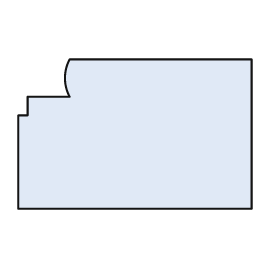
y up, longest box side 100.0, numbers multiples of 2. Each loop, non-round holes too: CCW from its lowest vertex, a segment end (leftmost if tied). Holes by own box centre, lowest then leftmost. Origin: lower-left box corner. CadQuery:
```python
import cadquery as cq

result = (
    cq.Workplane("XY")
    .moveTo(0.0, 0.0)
    .lineTo(100.0, 0.0)
    .lineTo(100.0, 64.0)
    .lineTo(22.0, 64.0)
    .threePointArc((20.0, 56.0), (22.0, 48.0))
    .lineTo(4.0, 48.0)
    .lineTo(4.0, 40.0)
    .lineTo(0.0, 40.0)
    .close()
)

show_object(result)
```